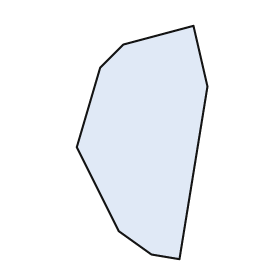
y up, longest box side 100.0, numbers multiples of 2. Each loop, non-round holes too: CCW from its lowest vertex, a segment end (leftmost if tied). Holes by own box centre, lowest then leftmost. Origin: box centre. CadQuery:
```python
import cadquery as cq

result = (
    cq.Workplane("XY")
    .moveTo(16.0, -50.0)
    .lineTo(28.0, 24.0)
    .lineTo(22.0, 50.0)
    .lineTo(-8.0, 42.0)
    .lineTo(-18.0, 32.0)
    .lineTo(-28.0, -2.0)
    .lineTo(-10.0, -38.0)
    .lineTo(4.0, -48.0)
    .close()
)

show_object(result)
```